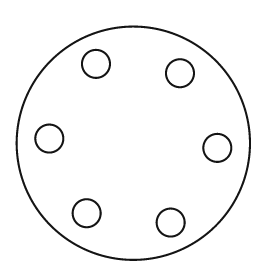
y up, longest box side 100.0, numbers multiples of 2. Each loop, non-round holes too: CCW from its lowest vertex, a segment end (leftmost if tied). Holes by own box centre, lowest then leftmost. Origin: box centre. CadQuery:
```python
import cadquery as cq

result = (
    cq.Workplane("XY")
    .moveTo(0.0, 0.0)
    .circle(50.0)
    .moveTo(16.0, -34.0)
    .circle(6.0)
    .moveTo(-20.0, -30.0)
    .circle(6.0)
    .moveTo(36.0, -2.0)
    .circle(6.0)
    .moveTo(-36.0, 2.0)
    .circle(6.0)
    .moveTo(20.0, 30.0)
    .circle(6.0)
    .moveTo(-16.0, 34.0)
    .circle(6.0)
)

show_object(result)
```